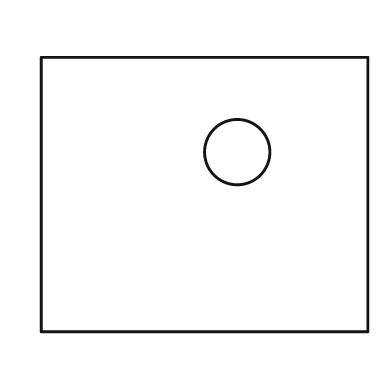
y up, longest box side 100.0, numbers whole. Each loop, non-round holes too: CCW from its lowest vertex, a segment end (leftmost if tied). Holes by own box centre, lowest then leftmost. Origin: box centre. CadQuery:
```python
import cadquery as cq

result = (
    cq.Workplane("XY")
    .moveTo(-50.0, -42.0)
    .lineTo(50.0, -42.0)
    .lineTo(50.0, 42.0)
    .lineTo(-50.0, 42.0)
    .close()
    .moveTo(10.0, 13.0)
    .circle(10.0)
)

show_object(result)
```